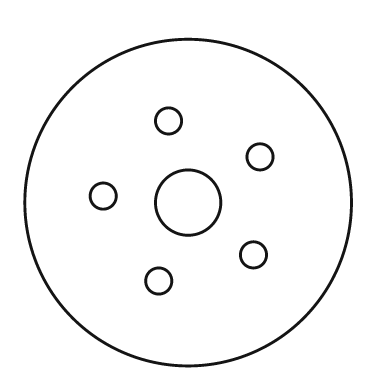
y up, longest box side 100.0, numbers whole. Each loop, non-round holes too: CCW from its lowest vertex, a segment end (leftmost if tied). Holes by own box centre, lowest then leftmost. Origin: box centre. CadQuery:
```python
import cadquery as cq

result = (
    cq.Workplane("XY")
    .moveTo(0.0, 0.0)
    .circle(50.0)
    .moveTo(-9.0, -24.0)
    .circle(4.0)
    .moveTo(20.0, -16.0)
    .circle(4.0)
    .moveTo(0.0, 0.0)
    .circle(10.0)
    .moveTo(-26.0, 2.0)
    .circle(4.0)
    .moveTo(22.0, 14.0)
    .circle(4.0)
    .moveTo(-6.0, 25.0)
    .circle(4.0)
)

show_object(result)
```